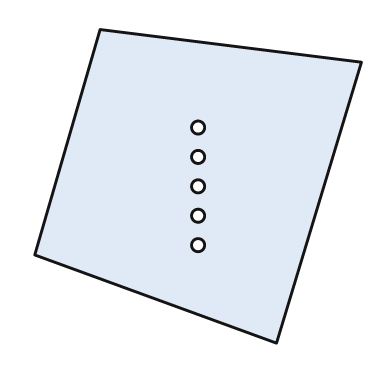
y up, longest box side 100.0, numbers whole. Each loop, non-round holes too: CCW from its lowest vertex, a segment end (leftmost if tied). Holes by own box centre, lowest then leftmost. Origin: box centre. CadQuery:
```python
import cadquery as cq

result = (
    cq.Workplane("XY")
    .moveTo(24.0, -48.0)
    .lineTo(50.0, 38.0)
    .lineTo(-30.0, 48.0)
    .lineTo(-50.0, -21.0)
    .close()
    .moveTo(0.0, -18.0)
    .circle(2.0)
    .moveTo(0.0, -9.0)
    .circle(2.0)
    .moveTo(0.0, 0.0)
    .circle(2.0)
    .moveTo(0.0, 9.0)
    .circle(2.0)
    .moveTo(0.0, 18.0)
    .circle(2.0)
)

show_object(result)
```